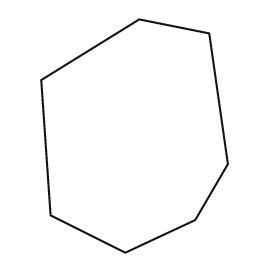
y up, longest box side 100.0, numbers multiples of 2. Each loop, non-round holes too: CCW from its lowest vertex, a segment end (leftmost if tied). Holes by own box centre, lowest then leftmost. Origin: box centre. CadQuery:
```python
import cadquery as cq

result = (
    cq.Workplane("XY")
    .moveTo(-4.0, -50.0)
    .lineTo(26.0, -36.0)
    .lineTo(40.0, -12.0)
    .lineTo(32.0, 44.0)
    .lineTo(2.0, 50.0)
    .lineTo(-40.0, 24.0)
    .lineTo(-36.0, -34.0)
    .close()
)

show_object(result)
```